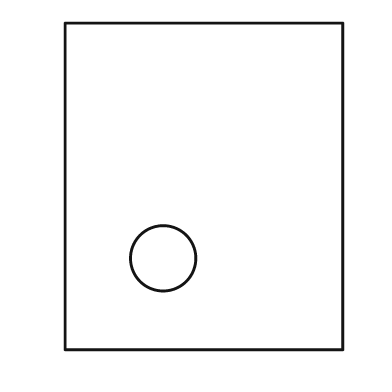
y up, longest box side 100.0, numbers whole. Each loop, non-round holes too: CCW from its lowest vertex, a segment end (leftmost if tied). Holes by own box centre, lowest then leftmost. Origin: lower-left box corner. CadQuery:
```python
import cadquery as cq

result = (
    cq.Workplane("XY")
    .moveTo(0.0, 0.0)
    .lineTo(85.0, 0.0)
    .lineTo(85.0, 100.0)
    .lineTo(0.0, 100.0)
    .close()
    .moveTo(30.0, 28.0)
    .circle(10.0)
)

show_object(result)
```